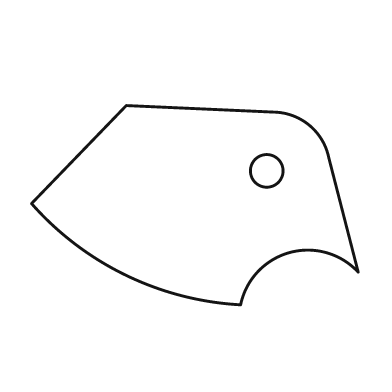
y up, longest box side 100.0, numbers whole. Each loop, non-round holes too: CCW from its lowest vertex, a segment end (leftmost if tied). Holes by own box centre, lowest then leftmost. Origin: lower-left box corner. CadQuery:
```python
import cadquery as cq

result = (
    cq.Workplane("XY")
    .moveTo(64.0, 0.0)
    .threePointArc((79.0, 16.0), (100.0, 10.0))
    .lineTo(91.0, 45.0)
    .threePointArc((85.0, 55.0), (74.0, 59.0))
    .lineTo(29.0, 61.0)
    .lineTo(0.0, 31.0)
    .threePointArc((29.0, 9.0), (64.0, 0.0))
    .close()
    .moveTo(72.0, 41.0)
    .circle(5.0)
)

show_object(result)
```